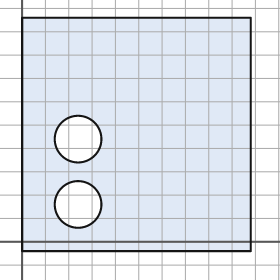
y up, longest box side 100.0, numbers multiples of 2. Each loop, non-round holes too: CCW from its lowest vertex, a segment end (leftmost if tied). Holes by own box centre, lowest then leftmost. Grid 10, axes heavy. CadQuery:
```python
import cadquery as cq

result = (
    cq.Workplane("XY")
    .moveTo(0.0, -4.0)
    .lineTo(98.0, -4.0)
    .lineTo(98.0, 96.0)
    .lineTo(0.0, 96.0)
    .close()
    .moveTo(24.0, 16.0)
    .circle(10.0)
    .moveTo(24.0, 44.0)
    .circle(10.0)
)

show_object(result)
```